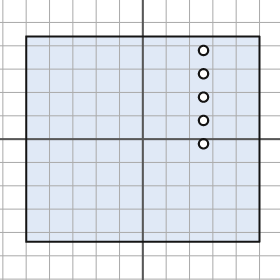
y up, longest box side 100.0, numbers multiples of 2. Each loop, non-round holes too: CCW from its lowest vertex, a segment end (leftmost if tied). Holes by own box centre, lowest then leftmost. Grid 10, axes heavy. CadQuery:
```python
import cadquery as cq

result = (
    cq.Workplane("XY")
    .moveTo(-50.0, -44.0)
    .lineTo(50.0, -44.0)
    .lineTo(50.0, 44.0)
    .lineTo(-50.0, 44.0)
    .close()
    .moveTo(26.0, -2.0)
    .circle(2.0)
    .moveTo(26.0, 8.0)
    .circle(2.0)
    .moveTo(26.0, 18.0)
    .circle(2.0)
    .moveTo(26.0, 28.0)
    .circle(2.0)
    .moveTo(26.0, 38.0)
    .circle(2.0)
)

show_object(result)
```